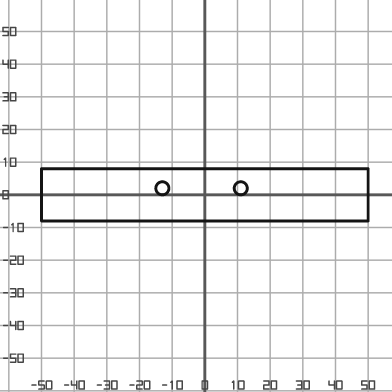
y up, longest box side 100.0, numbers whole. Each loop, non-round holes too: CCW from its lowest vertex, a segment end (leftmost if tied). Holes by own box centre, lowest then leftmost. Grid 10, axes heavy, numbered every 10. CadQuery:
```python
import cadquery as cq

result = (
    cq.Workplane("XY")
    .moveTo(-50.0, -8.0)
    .lineTo(50.0, -8.0)
    .lineTo(50.0, 8.0)
    .lineTo(-50.0, 8.0)
    .close()
    .moveTo(-13.0, 2.0)
    .circle(2.0)
    .moveTo(11.0, 2.0)
    .circle(2.0)
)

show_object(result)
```